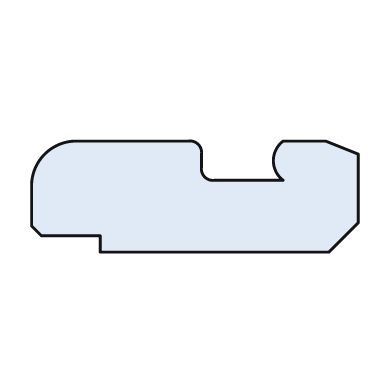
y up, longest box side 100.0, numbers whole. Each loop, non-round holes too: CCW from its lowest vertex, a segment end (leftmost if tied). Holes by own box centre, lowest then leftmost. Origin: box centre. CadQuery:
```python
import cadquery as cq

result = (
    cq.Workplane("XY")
    .moveTo(-29.0, -17.0)
    .lineTo(41.0, -17.0)
    .lineTo(50.0, -8.0)
    .lineTo(50.0, 13.0)
    .lineTo(40.0, 17.0)
    .lineTo(27.0, 17.0)
    .threePointArc((24.0, 11.0), (27.0, 5.0))
    .lineTo(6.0, 5.0)
    .threePointArc((3.0, 6.0), (2.0, 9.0))
    .lineTo(2.0, 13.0)
    .threePointArc((1.0, 16.0), (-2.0, 17.0))
    .lineTo(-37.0, 17.0)
    .threePointArc((-46.0, 13.0), (-50.0, 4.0))
    .lineTo(-50.0, -9.0)
    .lineTo(-47.0, -12.0)
    .lineTo(-29.0, -12.0)
    .close()
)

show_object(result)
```